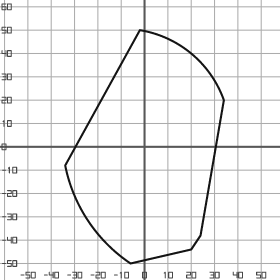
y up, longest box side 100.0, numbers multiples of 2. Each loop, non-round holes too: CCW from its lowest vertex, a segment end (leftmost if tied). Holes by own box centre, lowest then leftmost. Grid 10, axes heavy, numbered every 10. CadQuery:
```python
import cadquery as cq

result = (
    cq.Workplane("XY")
    .moveTo(-6.0, -50.0)
    .lineTo(20.0, -44.0)
    .lineTo(24.0, -38.0)
    .lineTo(34.0, 20.0)
    .threePointArc((20.0, 40.0), (-2.0, 50.0))
    .lineTo(-34.0, -8.0)
    .threePointArc((-24.0, -32.0), (-6.0, -50.0))
    .close()
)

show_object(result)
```